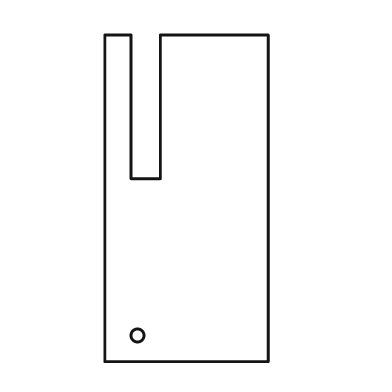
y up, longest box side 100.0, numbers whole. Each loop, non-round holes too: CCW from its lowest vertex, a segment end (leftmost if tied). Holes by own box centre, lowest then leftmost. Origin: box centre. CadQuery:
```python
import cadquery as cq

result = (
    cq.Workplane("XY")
    .moveTo(-25.0, -50.0)
    .lineTo(25.0, -50.0)
    .lineTo(25.0, 50.0)
    .lineTo(-8.0, 50.0)
    .lineTo(-8.0, 6.0)
    .lineTo(-17.0, 6.0)
    .lineTo(-17.0, 50.0)
    .lineTo(-25.0, 50.0)
    .close()
    .moveTo(-15.0, -42.0)
    .circle(2.0)
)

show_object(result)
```